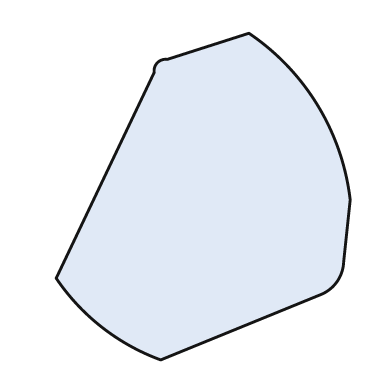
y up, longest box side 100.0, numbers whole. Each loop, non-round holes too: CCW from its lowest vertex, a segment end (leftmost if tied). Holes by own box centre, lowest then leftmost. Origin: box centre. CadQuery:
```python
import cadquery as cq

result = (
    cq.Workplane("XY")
    .moveTo(-13.0, -50.0)
    .lineTo(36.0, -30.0)
    .threePointArc((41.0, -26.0), (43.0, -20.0))
    .lineTo(45.0, -1.0)
    .threePointArc((35.0, 28.0), (14.0, 50.0))
    .lineTo(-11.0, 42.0)
    .threePointArc((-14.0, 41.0), (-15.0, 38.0))
    .lineTo(-45.0, -25.0)
    .threePointArc((-31.0, -40.0), (-13.0, -50.0))
    .close()
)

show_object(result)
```